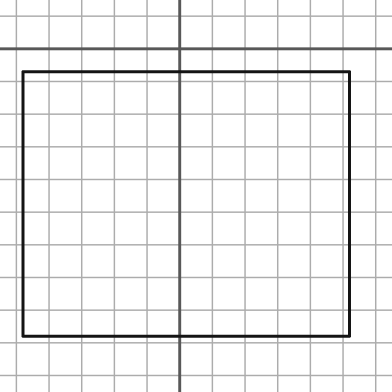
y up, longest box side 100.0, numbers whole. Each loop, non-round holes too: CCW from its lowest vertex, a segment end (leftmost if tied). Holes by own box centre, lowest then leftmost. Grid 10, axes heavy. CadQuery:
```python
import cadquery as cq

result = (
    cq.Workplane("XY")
    .moveTo(-48.0, -88.0)
    .lineTo(52.0, -88.0)
    .lineTo(52.0, -7.0)
    .lineTo(-48.0, -7.0)
    .close()
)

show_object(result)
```